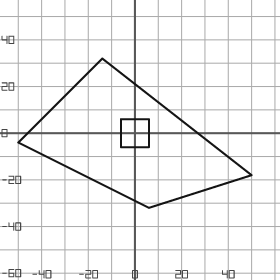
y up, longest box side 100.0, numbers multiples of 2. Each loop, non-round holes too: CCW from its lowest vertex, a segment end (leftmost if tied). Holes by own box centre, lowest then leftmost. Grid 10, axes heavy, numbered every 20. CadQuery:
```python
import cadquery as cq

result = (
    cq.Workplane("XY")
    .moveTo(6.0, -32.0)
    .lineTo(50.0, -18.0)
    .lineTo(-14.0, 32.0)
    .lineTo(-50.0, -4.0)
    .close()
    .moveTo(-6.0, -6.0)
    .lineTo(6.0, -6.0)
    .lineTo(6.0, 6.0)
    .lineTo(-6.0, 6.0)
    .close()
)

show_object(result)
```